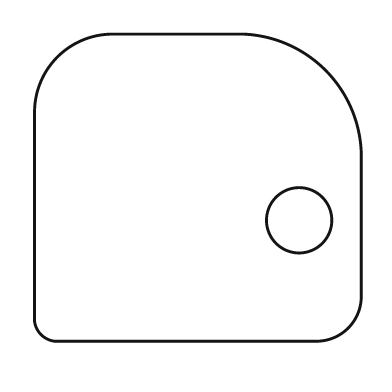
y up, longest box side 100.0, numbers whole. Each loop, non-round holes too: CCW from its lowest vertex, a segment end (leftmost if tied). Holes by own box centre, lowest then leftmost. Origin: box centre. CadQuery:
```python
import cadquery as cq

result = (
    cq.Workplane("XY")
    .moveTo(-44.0, -47.0)
    .lineTo(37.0, -47.0)
    .threePointArc((46.0, -43.0), (50.0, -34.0))
    .lineTo(50.0, 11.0)
    .threePointArc((39.0, 36.0), (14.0, 47.0))
    .lineTo(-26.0, 47.0)
    .threePointArc((-43.0, 40.0), (-50.0, 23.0))
    .lineTo(-50.0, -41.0)
    .threePointArc((-48.0, -45.0), (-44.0, -47.0))
    .close()
    .moveTo(31.0, -10.0)
    .circle(10.0)
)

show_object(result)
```